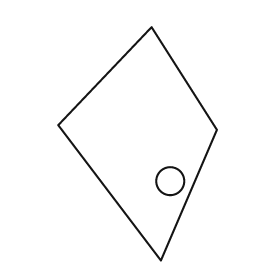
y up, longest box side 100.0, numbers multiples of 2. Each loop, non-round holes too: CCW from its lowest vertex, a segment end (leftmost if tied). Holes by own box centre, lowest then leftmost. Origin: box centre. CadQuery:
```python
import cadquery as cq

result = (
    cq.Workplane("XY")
    .moveTo(10.0, -50.0)
    .lineTo(34.0, 6.0)
    .lineTo(6.0, 50.0)
    .lineTo(-34.0, 8.0)
    .close()
    .moveTo(14.0, -16.0)
    .circle(6.0)
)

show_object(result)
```